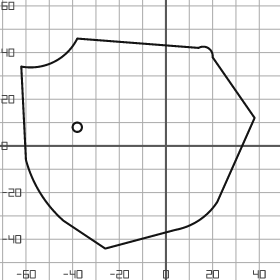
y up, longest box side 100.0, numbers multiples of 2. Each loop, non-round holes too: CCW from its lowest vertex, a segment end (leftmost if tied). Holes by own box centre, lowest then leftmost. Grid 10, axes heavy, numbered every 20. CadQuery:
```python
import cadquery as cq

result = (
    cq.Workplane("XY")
    .moveTo(-26.0, -44.0)
    .lineTo(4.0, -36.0)
    .threePointArc((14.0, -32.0), (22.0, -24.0))
    .lineTo(38.0, 12.0)
    .lineTo(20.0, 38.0)
    .threePointArc((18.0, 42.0), (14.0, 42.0))
    .lineTo(-38.0, 46.0)
    .threePointArc((-48.0, 36.0), (-62.0, 34.0))
    .lineTo(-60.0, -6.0)
    .threePointArc((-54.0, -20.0), (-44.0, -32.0))
    .close()
    .moveTo(-38.0, 8.0)
    .circle(2.0)
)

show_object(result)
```